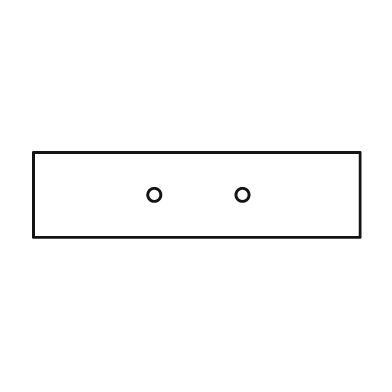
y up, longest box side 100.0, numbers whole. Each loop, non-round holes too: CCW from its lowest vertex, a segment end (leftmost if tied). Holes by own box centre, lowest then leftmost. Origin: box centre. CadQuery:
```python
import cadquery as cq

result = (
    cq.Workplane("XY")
    .moveTo(-50.0, -13.0)
    .lineTo(50.0, -13.0)
    .lineTo(50.0, 13.0)
    .lineTo(-50.0, 13.0)
    .close()
    .moveTo(-13.0, 0.0)
    .circle(2.0)
    .moveTo(14.0, 0.0)
    .circle(2.0)
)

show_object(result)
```